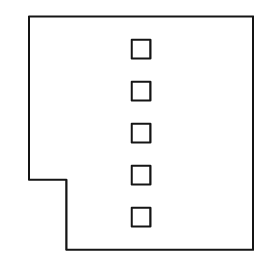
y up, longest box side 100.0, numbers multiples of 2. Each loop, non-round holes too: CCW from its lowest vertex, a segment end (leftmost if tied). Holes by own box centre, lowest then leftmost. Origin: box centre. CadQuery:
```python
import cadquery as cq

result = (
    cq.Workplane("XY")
    .moveTo(-32.0, -50.0)
    .lineTo(48.0, -50.0)
    .lineTo(48.0, 50.0)
    .lineTo(-48.0, 50.0)
    .lineTo(-48.0, -20.0)
    .lineTo(-32.0, -20.0)
    .close()
    .moveTo(-4.0, -40.0)
    .lineTo(4.0, -40.0)
    .lineTo(4.0, -32.0)
    .lineTo(-4.0, -32.0)
    .close()
    .moveTo(-4.0, -22.0)
    .lineTo(4.0, -22.0)
    .lineTo(4.0, -14.0)
    .lineTo(-4.0, -14.0)
    .close()
    .moveTo(-4.0, -4.0)
    .lineTo(4.0, -4.0)
    .lineTo(4.0, 4.0)
    .lineTo(-4.0, 4.0)
    .close()
    .moveTo(-4.0, 14.0)
    .lineTo(4.0, 14.0)
    .lineTo(4.0, 22.0)
    .lineTo(-4.0, 22.0)
    .close()
    .moveTo(-4.0, 32.0)
    .lineTo(4.0, 32.0)
    .lineTo(4.0, 40.0)
    .lineTo(-4.0, 40.0)
    .close()
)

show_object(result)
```